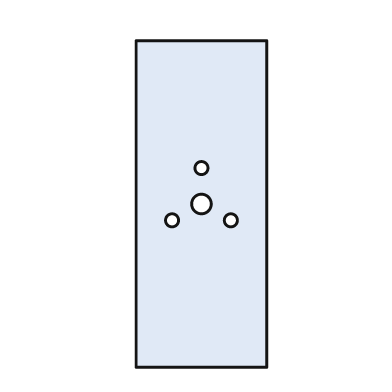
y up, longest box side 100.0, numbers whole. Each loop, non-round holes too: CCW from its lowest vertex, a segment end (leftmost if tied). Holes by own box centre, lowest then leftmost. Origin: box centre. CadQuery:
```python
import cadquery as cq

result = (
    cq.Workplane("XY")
    .moveTo(-20.0, -50.0)
    .lineTo(20.0, -50.0)
    .lineTo(20.0, 50.0)
    .lineTo(-20.0, 50.0)
    .close()
    .moveTo(-9.0, -5.0)
    .circle(2.0)
    .moveTo(9.0, -5.0)
    .circle(2.0)
    .moveTo(0.0, 0.0)
    .circle(3.0)
    .moveTo(0.0, 11.0)
    .circle(2.0)
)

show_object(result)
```